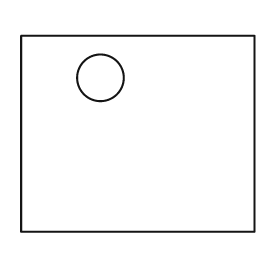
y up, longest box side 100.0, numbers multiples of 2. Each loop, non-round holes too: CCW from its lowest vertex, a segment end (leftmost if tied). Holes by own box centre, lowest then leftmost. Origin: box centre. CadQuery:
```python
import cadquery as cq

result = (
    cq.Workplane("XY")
    .moveTo(-50.0, -42.0)
    .lineTo(50.0, -42.0)
    .lineTo(50.0, 42.0)
    .lineTo(-50.0, 42.0)
    .close()
    .moveTo(-16.0, 24.0)
    .circle(10.0)
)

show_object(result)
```